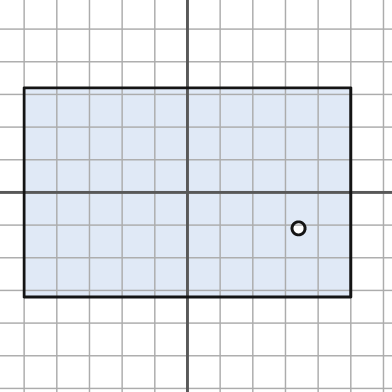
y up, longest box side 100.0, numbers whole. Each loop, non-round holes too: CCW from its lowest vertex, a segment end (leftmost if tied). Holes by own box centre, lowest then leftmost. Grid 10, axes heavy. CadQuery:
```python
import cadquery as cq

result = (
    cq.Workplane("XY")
    .moveTo(-50.0, -32.0)
    .lineTo(50.0, -32.0)
    .lineTo(50.0, 32.0)
    .lineTo(-50.0, 32.0)
    .close()
    .moveTo(34.0, -11.0)
    .circle(2.0)
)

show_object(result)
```